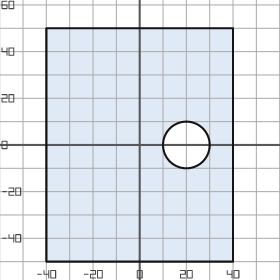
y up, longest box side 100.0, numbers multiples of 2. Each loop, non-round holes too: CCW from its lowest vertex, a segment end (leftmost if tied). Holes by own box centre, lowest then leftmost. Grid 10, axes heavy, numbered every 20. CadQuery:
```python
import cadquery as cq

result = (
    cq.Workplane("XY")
    .moveTo(-40.0, -50.0)
    .lineTo(40.0, -50.0)
    .lineTo(40.0, 50.0)
    .lineTo(-40.0, 50.0)
    .close()
    .moveTo(20.0, 0.0)
    .circle(10.0)
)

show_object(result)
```